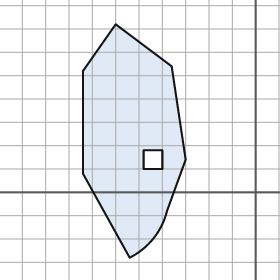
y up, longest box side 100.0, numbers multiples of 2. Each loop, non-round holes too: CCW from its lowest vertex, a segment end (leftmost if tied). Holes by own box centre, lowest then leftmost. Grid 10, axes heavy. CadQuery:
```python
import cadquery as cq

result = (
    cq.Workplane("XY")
    .moveTo(-54.0, -28.0)
    .threePointArc((-44.0, -20.0), (-38.0, -8.0))
    .lineTo(-30.0, 14.0)
    .lineTo(-36.0, 54.0)
    .lineTo(-60.0, 72.0)
    .lineTo(-74.0, 52.0)
    .lineTo(-74.0, 8.0)
    .close()
    .moveTo(-48.0, 10.0)
    .lineTo(-40.0, 10.0)
    .lineTo(-40.0, 18.0)
    .lineTo(-48.0, 18.0)
    .close()
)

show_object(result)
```